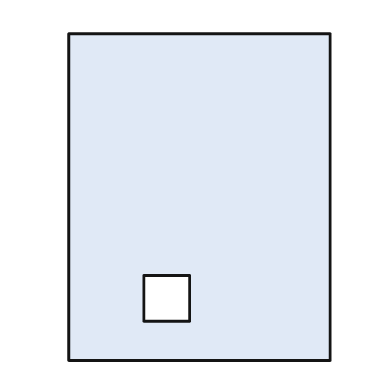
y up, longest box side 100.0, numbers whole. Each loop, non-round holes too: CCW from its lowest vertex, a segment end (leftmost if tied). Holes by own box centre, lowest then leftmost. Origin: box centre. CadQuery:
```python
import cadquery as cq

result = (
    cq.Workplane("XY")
    .moveTo(-40.0, -50.0)
    .lineTo(40.0, -50.0)
    .lineTo(40.0, 50.0)
    .lineTo(-40.0, 50.0)
    .close()
    .moveTo(-17.0, -38.0)
    .lineTo(-3.0, -38.0)
    .lineTo(-3.0, -24.0)
    .lineTo(-17.0, -24.0)
    .close()
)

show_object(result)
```